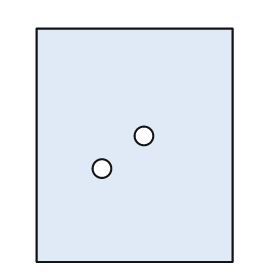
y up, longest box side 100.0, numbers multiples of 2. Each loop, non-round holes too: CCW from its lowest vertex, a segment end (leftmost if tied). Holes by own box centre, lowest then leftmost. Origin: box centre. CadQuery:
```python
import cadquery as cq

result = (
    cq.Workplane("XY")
    .moveTo(-42.0, -50.0)
    .lineTo(42.0, -50.0)
    .lineTo(42.0, 50.0)
    .lineTo(-42.0, 50.0)
    .close()
    .moveTo(-14.0, -10.0)
    .circle(4.0)
    .moveTo(4.0, 4.0)
    .circle(4.0)
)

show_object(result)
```